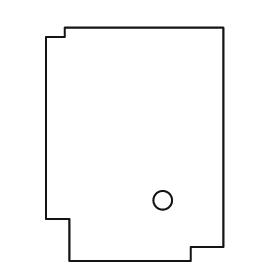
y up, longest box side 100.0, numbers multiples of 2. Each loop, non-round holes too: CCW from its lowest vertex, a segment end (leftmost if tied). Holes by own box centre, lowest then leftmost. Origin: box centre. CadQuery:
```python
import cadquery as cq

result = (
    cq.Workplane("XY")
    .moveTo(-28.0, -50.0)
    .lineTo(24.0, -50.0)
    .lineTo(24.0, -44.0)
    .lineTo(38.0, -44.0)
    .lineTo(38.0, 50.0)
    .lineTo(-30.0, 50.0)
    .lineTo(-30.0, 46.0)
    .lineTo(-38.0, 46.0)
    .lineTo(-38.0, -32.0)
    .lineTo(-28.0, -32.0)
    .close()
    .moveTo(12.0, -24.0)
    .circle(4.0)
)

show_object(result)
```